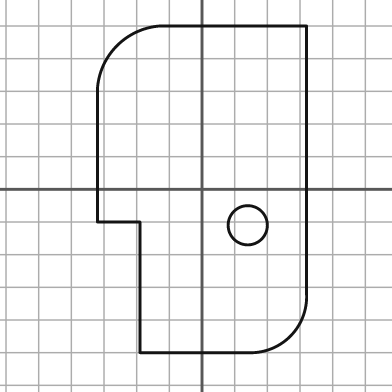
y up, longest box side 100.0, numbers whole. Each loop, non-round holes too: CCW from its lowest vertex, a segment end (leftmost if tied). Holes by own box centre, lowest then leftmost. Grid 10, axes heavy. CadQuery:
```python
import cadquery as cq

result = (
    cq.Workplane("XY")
    .moveTo(-19.0, -50.0)
    .lineTo(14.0, -50.0)
    .threePointArc((27.0, -45.0), (32.0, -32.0))
    .lineTo(32.0, 50.0)
    .lineTo(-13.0, 50.0)
    .threePointArc((-26.0, 44.0), (-32.0, 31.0))
    .lineTo(-32.0, -10.0)
    .lineTo(-19.0, -10.0)
    .close()
    .moveTo(14.0, -11.0)
    .circle(6.0)
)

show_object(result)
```